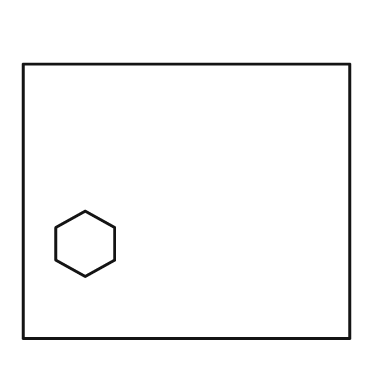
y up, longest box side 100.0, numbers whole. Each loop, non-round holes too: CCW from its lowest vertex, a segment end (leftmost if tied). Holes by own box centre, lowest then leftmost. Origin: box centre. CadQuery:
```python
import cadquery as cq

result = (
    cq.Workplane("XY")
    .moveTo(-50.0, -42.0)
    .lineTo(50.0, -42.0)
    .lineTo(50.0, 42.0)
    .lineTo(-50.0, 42.0)
    .close()
    .moveTo(-31.0, -23.0)
    .lineTo(-22.0, -18.0)
    .lineTo(-22.0, -8.0)
    .lineTo(-31.0, -3.0)
    .lineTo(-40.0, -8.0)
    .lineTo(-40.0, -18.0)
    .close()
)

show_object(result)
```